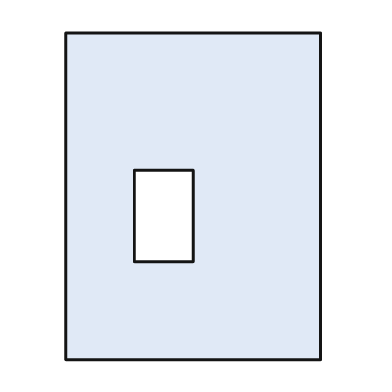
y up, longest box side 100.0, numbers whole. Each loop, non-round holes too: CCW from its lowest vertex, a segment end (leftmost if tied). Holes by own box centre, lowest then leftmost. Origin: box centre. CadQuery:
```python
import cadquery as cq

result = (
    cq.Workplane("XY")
    .moveTo(-39.0, -50.0)
    .lineTo(39.0, -50.0)
    .lineTo(39.0, 50.0)
    .lineTo(-39.0, 50.0)
    .close()
    .moveTo(-18.0, -20.0)
    .lineTo(0.0, -20.0)
    .lineTo(0.0, 8.0)
    .lineTo(-18.0, 8.0)
    .close()
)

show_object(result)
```